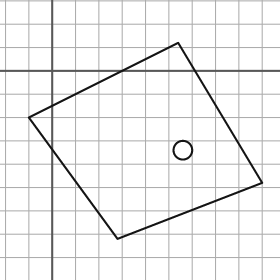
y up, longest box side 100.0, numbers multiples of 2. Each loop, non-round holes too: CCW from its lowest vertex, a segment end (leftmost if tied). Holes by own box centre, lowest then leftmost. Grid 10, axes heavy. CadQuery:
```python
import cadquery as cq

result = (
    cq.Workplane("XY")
    .moveTo(28.0, -72.0)
    .lineTo(90.0, -48.0)
    .lineTo(54.0, 12.0)
    .lineTo(-10.0, -20.0)
    .close()
    .moveTo(56.0, -34.0)
    .circle(4.0)
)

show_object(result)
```